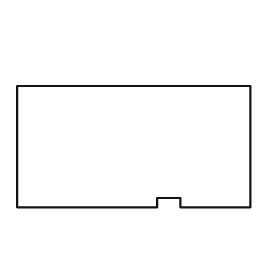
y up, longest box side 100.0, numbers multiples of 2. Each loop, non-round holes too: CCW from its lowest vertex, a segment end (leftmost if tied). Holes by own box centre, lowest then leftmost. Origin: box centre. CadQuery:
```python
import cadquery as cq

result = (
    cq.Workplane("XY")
    .moveTo(-50.0, -26.0)
    .lineTo(10.0, -26.0)
    .lineTo(10.0, -22.0)
    .lineTo(20.0, -22.0)
    .lineTo(20.0, -26.0)
    .lineTo(50.0, -26.0)
    .lineTo(50.0, 26.0)
    .lineTo(-50.0, 26.0)
    .close()
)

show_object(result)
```